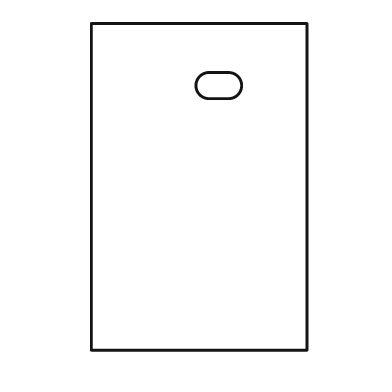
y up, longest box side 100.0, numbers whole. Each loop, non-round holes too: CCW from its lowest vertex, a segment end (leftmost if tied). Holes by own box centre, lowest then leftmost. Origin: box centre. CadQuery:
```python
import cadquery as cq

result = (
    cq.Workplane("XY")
    .moveTo(-33.0, -50.0)
    .lineTo(33.0, -50.0)
    .lineTo(33.0, 50.0)
    .lineTo(-33.0, 50.0)
    .close()
    .moveTo(3.0, 27.0)
    .lineTo(9.0, 27.0)
    .threePointArc((13.0, 31.0), (9.0, 35.0))
    .lineTo(3.0, 35.0)
    .threePointArc((-1.0, 31.0), (3.0, 27.0))
    .close()
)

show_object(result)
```